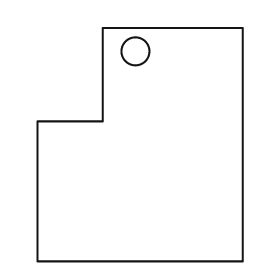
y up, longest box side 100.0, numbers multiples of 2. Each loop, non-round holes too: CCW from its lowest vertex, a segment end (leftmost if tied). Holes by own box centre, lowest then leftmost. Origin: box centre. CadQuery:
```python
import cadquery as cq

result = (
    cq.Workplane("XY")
    .moveTo(-44.0, -50.0)
    .lineTo(44.0, -50.0)
    .lineTo(44.0, 50.0)
    .lineTo(-16.0, 50.0)
    .lineTo(-16.0, 10.0)
    .lineTo(-44.0, 10.0)
    .close()
    .moveTo(-2.0, 40.0)
    .circle(6.0)
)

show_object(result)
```